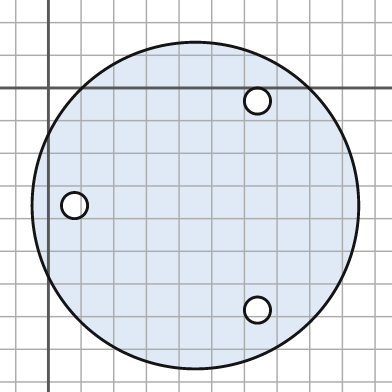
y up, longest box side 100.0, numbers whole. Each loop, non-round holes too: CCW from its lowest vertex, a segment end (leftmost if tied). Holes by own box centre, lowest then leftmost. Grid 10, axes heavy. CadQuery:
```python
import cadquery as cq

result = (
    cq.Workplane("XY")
    .moveTo(45.0, -36.0)
    .circle(50.0)
    .moveTo(64.0, -68.0)
    .circle(4.0)
    .moveTo(8.0, -36.0)
    .circle(4.0)
    .moveTo(64.0, -4.0)
    .circle(4.0)
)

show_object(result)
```